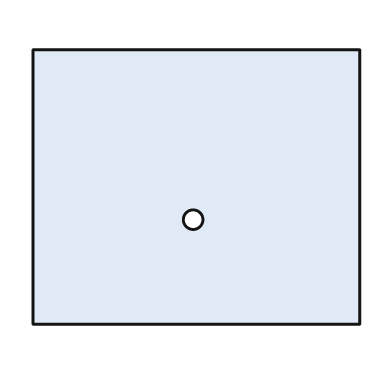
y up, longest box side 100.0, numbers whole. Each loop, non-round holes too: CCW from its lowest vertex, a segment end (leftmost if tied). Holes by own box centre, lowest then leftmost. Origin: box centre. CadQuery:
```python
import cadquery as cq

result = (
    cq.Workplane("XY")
    .moveTo(-50.0, -42.0)
    .lineTo(50.0, -42.0)
    .lineTo(50.0, 42.0)
    .lineTo(-50.0, 42.0)
    .close()
    .moveTo(-1.0, -10.0)
    .circle(3.0)
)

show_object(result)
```